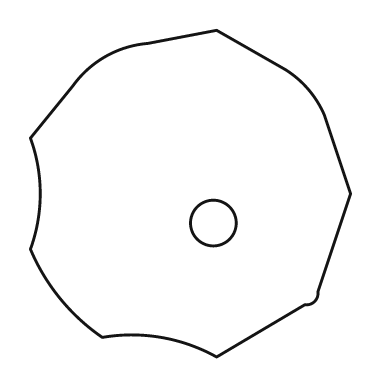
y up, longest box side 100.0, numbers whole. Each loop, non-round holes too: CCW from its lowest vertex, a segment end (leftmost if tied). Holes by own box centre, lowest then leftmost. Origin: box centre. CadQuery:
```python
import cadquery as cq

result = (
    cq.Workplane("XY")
    .moveTo(8.0, -50.0)
    .lineTo(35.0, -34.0)
    .threePointArc((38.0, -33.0), (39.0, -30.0))
    .lineTo(49.0, 0.0)
    .lineTo(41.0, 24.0)
    .threePointArc((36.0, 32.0), (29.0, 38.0))
    .lineTo(8.0, 50.0)
    .lineTo(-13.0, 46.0)
    .threePointArc((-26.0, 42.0), (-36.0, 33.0))
    .lineTo(-49.0, 17.0)
    .threePointArc((-46.0, 0.0), (-49.0, -17.0))
    .threePointArc((-40.0, -32.0), (-27.0, -44.0))
    .threePointArc((-9.0, -44.0), (8.0, -50.0))
    .close()
    .moveTo(7.0, -9.0)
    .circle(7.0)
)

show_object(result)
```